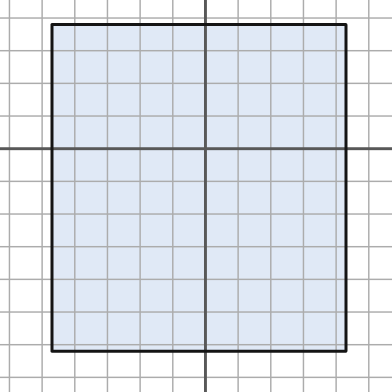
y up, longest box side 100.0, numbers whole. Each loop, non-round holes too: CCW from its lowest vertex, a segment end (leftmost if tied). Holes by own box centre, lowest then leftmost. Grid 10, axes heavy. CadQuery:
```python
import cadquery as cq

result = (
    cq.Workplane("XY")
    .moveTo(-47.0, -62.0)
    .lineTo(43.0, -62.0)
    .lineTo(43.0, 38.0)
    .lineTo(-47.0, 38.0)
    .close()
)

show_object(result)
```